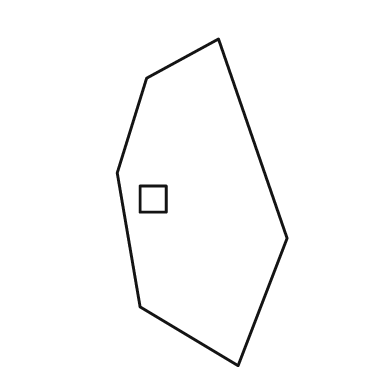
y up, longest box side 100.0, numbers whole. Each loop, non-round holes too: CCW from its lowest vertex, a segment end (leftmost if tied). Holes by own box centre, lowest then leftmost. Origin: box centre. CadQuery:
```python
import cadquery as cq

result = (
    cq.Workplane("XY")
    .moveTo(11.0, -50.0)
    .lineTo(26.0, -11.0)
    .lineTo(5.0, 50.0)
    .lineTo(-17.0, 38.0)
    .lineTo(-26.0, 9.0)
    .lineTo(-19.0, -32.0)
    .close()
    .moveTo(-19.0, -3.0)
    .lineTo(-11.0, -3.0)
    .lineTo(-11.0, 5.0)
    .lineTo(-19.0, 5.0)
    .close()
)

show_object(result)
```